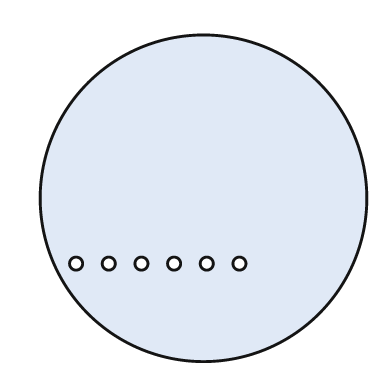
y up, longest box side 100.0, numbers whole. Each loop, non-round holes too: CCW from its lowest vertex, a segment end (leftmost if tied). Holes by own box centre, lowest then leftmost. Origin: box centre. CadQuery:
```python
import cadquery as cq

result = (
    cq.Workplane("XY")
    .moveTo(0.0, 0.0)
    .circle(50.0)
    .moveTo(-39.0, -20.0)
    .circle(2.0)
    .moveTo(-29.0, -20.0)
    .circle(2.0)
    .moveTo(-19.0, -20.0)
    .circle(2.0)
    .moveTo(-9.0, -20.0)
    .circle(2.0)
    .moveTo(1.0, -20.0)
    .circle(2.0)
    .moveTo(11.0, -20.0)
    .circle(2.0)
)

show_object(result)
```